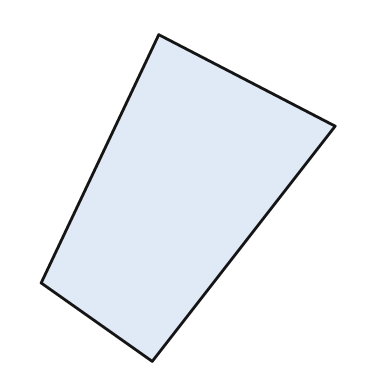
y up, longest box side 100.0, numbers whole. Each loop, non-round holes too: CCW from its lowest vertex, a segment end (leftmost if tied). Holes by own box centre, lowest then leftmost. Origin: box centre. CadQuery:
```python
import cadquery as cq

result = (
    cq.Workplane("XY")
    .moveTo(-11.0, -50.0)
    .lineTo(45.0, 22.0)
    .lineTo(-9.0, 50.0)
    .lineTo(-45.0, -26.0)
    .close()
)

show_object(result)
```